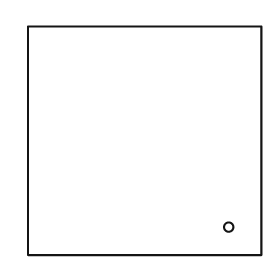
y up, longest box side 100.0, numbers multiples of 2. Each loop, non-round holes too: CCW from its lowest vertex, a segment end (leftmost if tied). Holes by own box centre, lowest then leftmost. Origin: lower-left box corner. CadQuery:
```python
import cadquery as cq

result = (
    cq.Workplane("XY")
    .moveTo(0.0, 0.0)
    .lineTo(100.0, 0.0)
    .lineTo(100.0, 98.0)
    .lineTo(0.0, 98.0)
    .close()
    .moveTo(86.0, 12.0)
    .circle(2.0)
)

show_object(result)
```